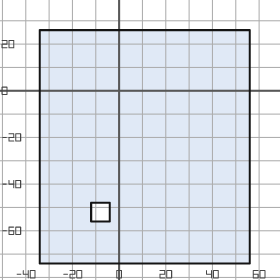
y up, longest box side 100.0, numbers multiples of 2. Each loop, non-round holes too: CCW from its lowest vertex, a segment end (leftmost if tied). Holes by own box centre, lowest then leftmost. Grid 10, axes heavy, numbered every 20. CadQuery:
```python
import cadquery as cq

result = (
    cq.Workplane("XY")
    .moveTo(-34.0, -74.0)
    .lineTo(56.0, -74.0)
    .lineTo(56.0, 26.0)
    .lineTo(-34.0, 26.0)
    .close()
    .moveTo(-12.0, -56.0)
    .lineTo(-4.0, -56.0)
    .lineTo(-4.0, -48.0)
    .lineTo(-12.0, -48.0)
    .close()
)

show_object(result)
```